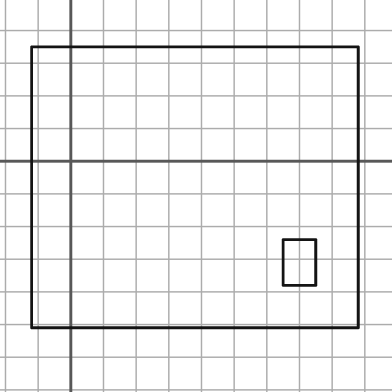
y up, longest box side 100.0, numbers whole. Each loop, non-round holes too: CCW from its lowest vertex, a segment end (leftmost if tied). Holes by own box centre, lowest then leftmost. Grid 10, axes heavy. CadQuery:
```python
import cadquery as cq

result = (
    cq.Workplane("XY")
    .moveTo(-12.0, -51.0)
    .lineTo(88.0, -51.0)
    .lineTo(88.0, 35.0)
    .lineTo(-12.0, 35.0)
    .close()
    .moveTo(65.0, -38.0)
    .lineTo(75.0, -38.0)
    .lineTo(75.0, -24.0)
    .lineTo(65.0, -24.0)
    .close()
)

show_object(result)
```